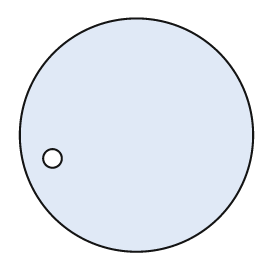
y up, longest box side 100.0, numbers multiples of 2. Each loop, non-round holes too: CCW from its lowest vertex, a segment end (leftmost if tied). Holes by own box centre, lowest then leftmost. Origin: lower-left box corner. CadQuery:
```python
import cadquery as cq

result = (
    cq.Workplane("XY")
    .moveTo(50.0, 50.0)
    .circle(50.0)
    .moveTo(14.0, 40.0)
    .circle(4.0)
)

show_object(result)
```